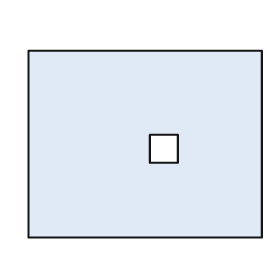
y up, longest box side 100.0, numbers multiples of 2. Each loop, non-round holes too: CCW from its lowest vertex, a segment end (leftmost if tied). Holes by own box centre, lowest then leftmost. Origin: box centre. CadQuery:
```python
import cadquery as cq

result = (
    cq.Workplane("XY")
    .moveTo(-50.0, -40.0)
    .lineTo(50.0, -40.0)
    .lineTo(50.0, 40.0)
    .lineTo(-50.0, 40.0)
    .close()
    .moveTo(2.0, -8.0)
    .lineTo(14.0, -8.0)
    .lineTo(14.0, 4.0)
    .lineTo(2.0, 4.0)
    .close()
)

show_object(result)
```